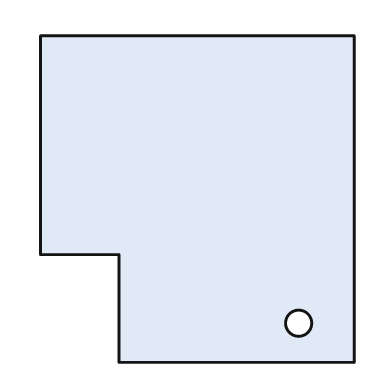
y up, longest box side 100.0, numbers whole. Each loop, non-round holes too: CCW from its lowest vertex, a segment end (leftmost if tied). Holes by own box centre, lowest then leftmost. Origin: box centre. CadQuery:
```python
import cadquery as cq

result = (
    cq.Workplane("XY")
    .moveTo(-24.0, -50.0)
    .lineTo(48.0, -50.0)
    .lineTo(48.0, 50.0)
    .lineTo(-48.0, 50.0)
    .lineTo(-48.0, -17.0)
    .lineTo(-24.0, -17.0)
    .close()
    .moveTo(31.0, -38.0)
    .circle(4.0)
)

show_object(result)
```